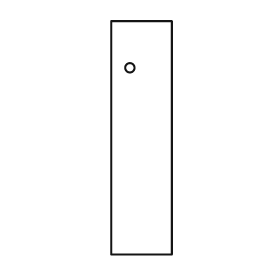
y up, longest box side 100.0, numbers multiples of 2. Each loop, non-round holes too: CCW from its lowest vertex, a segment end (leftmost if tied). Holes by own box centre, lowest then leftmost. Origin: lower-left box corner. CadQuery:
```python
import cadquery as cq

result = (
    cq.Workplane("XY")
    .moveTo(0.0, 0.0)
    .lineTo(26.0, 0.0)
    .lineTo(26.0, 100.0)
    .lineTo(0.0, 100.0)
    .close()
    .moveTo(8.0, 80.0)
    .circle(2.0)
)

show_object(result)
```